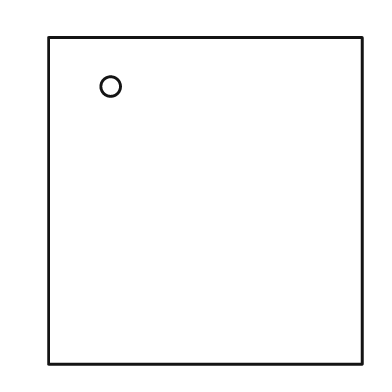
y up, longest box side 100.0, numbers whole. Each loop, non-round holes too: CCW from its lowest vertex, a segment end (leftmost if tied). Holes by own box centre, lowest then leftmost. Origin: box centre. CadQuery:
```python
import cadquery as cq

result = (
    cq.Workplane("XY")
    .moveTo(-48.0, -50.0)
    .lineTo(48.0, -50.0)
    .lineTo(48.0, 50.0)
    .lineTo(-48.0, 50.0)
    .close()
    .moveTo(-29.0, 35.0)
    .circle(3.0)
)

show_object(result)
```